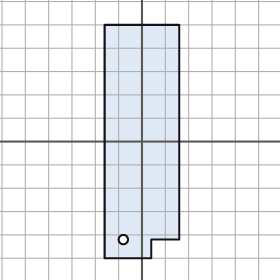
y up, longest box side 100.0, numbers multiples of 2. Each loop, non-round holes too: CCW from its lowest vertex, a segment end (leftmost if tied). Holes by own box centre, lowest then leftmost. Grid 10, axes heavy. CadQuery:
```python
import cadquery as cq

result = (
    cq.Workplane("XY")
    .moveTo(-16.0, -50.0)
    .lineTo(4.0, -50.0)
    .lineTo(4.0, -42.0)
    .lineTo(16.0, -42.0)
    .lineTo(16.0, 50.0)
    .lineTo(-16.0, 50.0)
    .close()
    .moveTo(-8.0, -42.0)
    .circle(2.0)
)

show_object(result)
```